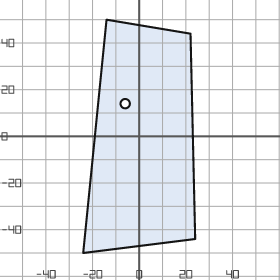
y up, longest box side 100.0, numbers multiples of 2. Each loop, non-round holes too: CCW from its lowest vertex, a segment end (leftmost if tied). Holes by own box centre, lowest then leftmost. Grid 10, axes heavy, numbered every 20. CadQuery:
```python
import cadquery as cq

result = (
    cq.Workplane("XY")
    .moveTo(-24.0, -50.0)
    .lineTo(24.0, -44.0)
    .lineTo(22.0, 44.0)
    .lineTo(-14.0, 50.0)
    .close()
    .moveTo(-6.0, 14.0)
    .circle(2.0)
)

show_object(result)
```